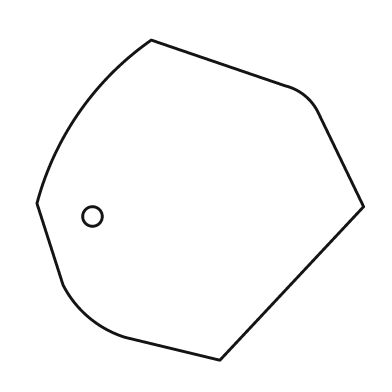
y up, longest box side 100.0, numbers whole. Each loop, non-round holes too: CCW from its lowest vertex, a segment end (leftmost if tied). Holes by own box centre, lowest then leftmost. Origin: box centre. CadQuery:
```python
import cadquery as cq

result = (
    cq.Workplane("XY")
    .moveTo(6.0, -49.0)
    .lineTo(50.0, -2.0)
    .lineTo(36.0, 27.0)
    .threePointArc((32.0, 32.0), (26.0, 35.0))
    .lineTo(-15.0, 49.0)
    .threePointArc((-37.0, 27.0), (-50.0, -1.0))
    .lineTo(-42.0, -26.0)
    .threePointArc((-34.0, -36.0), (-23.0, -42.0))
    .close()
    .moveTo(-33.0, -5.0)
    .circle(3.0)
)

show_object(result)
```